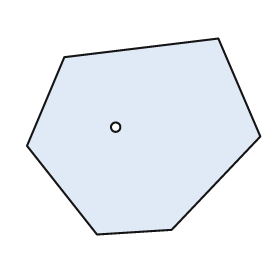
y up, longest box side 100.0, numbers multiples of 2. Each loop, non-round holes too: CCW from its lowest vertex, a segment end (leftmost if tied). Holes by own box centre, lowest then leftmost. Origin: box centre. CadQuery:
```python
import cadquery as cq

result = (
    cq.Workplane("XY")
    .moveTo(-20.0, -42.0)
    .lineTo(12.0, -40.0)
    .lineTo(50.0, 0.0)
    .lineTo(32.0, 42.0)
    .lineTo(-34.0, 34.0)
    .lineTo(-50.0, -4.0)
    .close()
    .moveTo(-12.0, 4.0)
    .circle(2.0)
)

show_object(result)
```